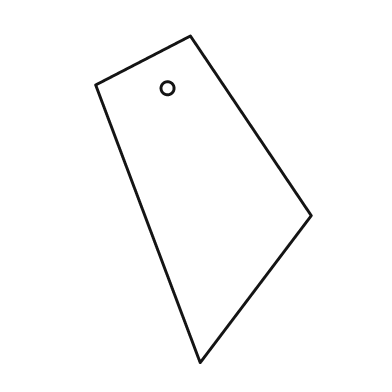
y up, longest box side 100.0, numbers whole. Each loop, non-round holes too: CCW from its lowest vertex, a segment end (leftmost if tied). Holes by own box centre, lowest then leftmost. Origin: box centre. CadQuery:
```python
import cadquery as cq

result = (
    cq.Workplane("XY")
    .moveTo(-1.0, -50.0)
    .lineTo(33.0, -5.0)
    .lineTo(-4.0, 50.0)
    .lineTo(-33.0, 35.0)
    .close()
    .moveTo(-11.0, 34.0)
    .circle(2.0)
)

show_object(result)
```